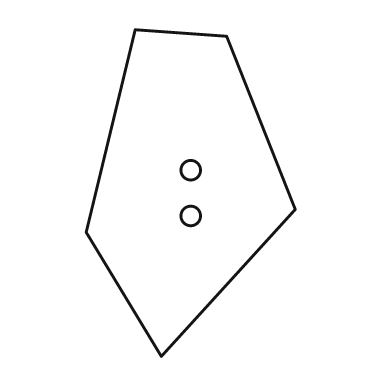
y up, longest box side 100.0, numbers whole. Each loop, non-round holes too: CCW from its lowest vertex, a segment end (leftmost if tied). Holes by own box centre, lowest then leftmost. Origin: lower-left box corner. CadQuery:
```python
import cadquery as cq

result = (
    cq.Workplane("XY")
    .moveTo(23.0, 0.0)
    .lineTo(64.0, 45.0)
    .lineTo(43.0, 98.0)
    .lineTo(15.0, 100.0)
    .lineTo(0.0, 38.0)
    .close()
    .moveTo(32.0, 43.0)
    .circle(3.0)
    .moveTo(32.0, 57.0)
    .circle(3.0)
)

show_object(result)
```